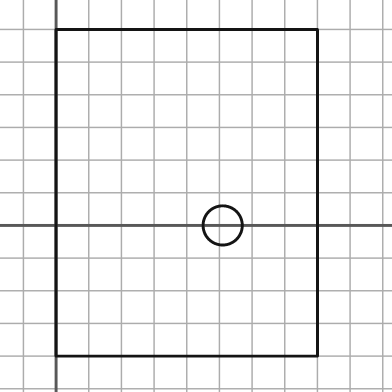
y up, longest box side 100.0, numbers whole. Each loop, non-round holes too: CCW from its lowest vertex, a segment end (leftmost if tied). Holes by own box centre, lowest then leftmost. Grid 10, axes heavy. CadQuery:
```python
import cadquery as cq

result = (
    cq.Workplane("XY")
    .moveTo(0.0, -40.0)
    .lineTo(80.0, -40.0)
    .lineTo(80.0, 60.0)
    .lineTo(0.0, 60.0)
    .close()
    .moveTo(51.0, 0.0)
    .circle(6.0)
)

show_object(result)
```